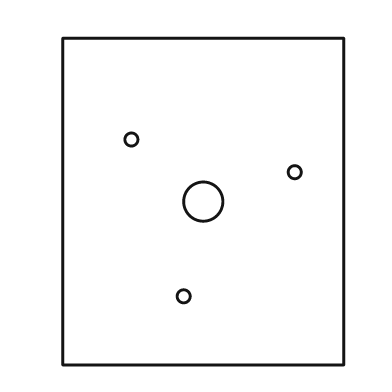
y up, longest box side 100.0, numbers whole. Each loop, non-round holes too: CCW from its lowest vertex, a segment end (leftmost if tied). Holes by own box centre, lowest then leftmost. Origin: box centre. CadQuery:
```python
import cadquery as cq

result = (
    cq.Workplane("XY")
    .moveTo(-43.0, -50.0)
    .lineTo(43.0, -50.0)
    .lineTo(43.0, 50.0)
    .lineTo(-43.0, 50.0)
    .close()
    .moveTo(-6.0, -29.0)
    .circle(2.0)
    .moveTo(0.0, 0.0)
    .circle(6.0)
    .moveTo(28.0, 9.0)
    .circle(2.0)
    .moveTo(-22.0, 19.0)
    .circle(2.0)
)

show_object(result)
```